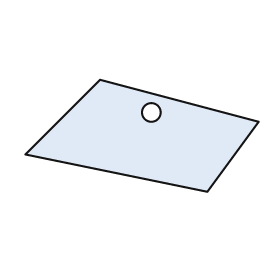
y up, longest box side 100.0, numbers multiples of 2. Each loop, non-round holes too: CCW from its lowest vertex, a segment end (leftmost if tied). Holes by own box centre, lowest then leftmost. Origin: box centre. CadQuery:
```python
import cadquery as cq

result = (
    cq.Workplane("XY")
    .moveTo(28.0, -24.0)
    .lineTo(50.0, 6.0)
    .lineTo(-18.0, 24.0)
    .lineTo(-50.0, -8.0)
    .close()
    .moveTo(4.0, 10.0)
    .circle(4.0)
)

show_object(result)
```